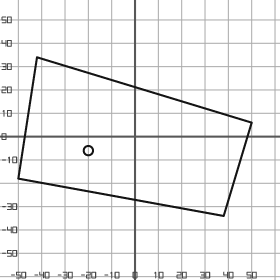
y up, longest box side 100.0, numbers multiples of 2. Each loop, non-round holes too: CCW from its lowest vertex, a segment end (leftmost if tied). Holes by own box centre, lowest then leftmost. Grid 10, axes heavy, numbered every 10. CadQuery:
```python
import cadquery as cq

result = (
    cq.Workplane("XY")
    .moveTo(38.0, -34.0)
    .lineTo(50.0, 6.0)
    .lineTo(-42.0, 34.0)
    .lineTo(-50.0, -18.0)
    .close()
    .moveTo(-20.0, -6.0)
    .circle(2.0)
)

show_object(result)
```